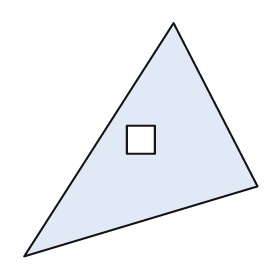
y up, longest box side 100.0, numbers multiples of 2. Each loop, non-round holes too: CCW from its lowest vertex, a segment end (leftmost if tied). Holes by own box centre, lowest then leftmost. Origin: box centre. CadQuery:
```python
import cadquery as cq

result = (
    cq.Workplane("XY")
    .moveTo(-50.0, -50.0)
    .lineTo(50.0, -20.0)
    .lineTo(14.0, 50.0)
    .close()
    .moveTo(-6.0, -6.0)
    .lineTo(6.0, -6.0)
    .lineTo(6.0, 6.0)
    .lineTo(-6.0, 6.0)
    .close()
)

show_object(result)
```